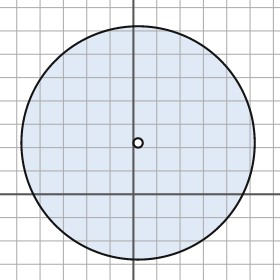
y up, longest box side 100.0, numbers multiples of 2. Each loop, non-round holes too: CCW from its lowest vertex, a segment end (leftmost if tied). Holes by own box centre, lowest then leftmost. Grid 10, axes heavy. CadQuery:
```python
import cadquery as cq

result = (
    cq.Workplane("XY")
    .moveTo(2.0, 22.0)
    .circle(50.0)
    .moveTo(2.0, 22.0)
    .circle(2.0)
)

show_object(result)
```